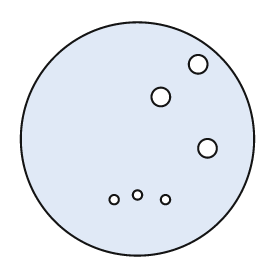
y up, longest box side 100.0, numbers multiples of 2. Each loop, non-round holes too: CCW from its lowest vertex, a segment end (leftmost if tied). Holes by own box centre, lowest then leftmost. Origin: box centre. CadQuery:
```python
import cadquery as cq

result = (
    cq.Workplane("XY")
    .moveTo(0.0, 0.0)
    .circle(50.0)
    .moveTo(-10.0, -26.0)
    .circle(2.0)
    .moveTo(12.0, -26.0)
    .circle(2.0)
    .moveTo(0.0, -24.0)
    .circle(2.0)
    .moveTo(30.0, -4.0)
    .circle(4.0)
    .moveTo(10.0, 18.0)
    .circle(4.0)
    .moveTo(26.0, 32.0)
    .circle(4.0)
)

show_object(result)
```